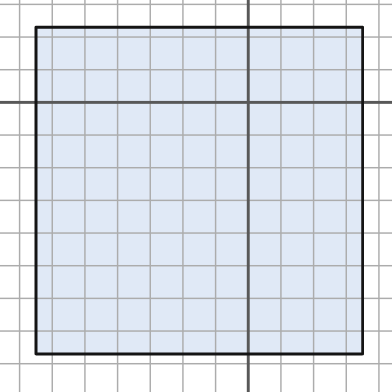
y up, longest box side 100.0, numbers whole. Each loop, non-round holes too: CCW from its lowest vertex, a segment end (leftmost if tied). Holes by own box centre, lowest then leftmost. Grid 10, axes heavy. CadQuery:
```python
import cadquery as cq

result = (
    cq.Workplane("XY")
    .moveTo(-65.0, -77.0)
    .lineTo(35.0, -77.0)
    .lineTo(35.0, 23.0)
    .lineTo(-65.0, 23.0)
    .close()
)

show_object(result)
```